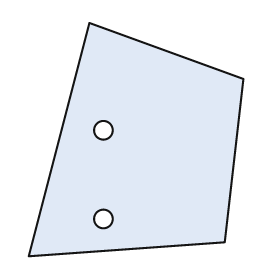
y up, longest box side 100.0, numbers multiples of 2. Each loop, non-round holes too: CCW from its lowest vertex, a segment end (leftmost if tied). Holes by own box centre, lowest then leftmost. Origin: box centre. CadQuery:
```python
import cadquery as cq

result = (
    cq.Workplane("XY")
    .moveTo(-46.0, -50.0)
    .lineTo(38.0, -44.0)
    .lineTo(46.0, 26.0)
    .lineTo(-20.0, 50.0)
    .close()
    .moveTo(-14.0, -34.0)
    .circle(4.0)
    .moveTo(-14.0, 4.0)
    .circle(4.0)
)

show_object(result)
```